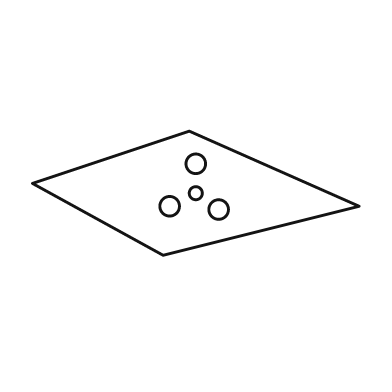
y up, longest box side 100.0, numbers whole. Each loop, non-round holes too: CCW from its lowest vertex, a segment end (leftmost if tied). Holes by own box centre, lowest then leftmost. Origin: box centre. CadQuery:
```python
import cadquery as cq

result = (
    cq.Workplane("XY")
    .moveTo(-10.0, -19.0)
    .lineTo(50.0, -4.0)
    .lineTo(-2.0, 19.0)
    .lineTo(-50.0, 3.0)
    .close()
    .moveTo(7.0, -5.0)
    .circle(3.0)
    .moveTo(-8.0, -4.0)
    .circle(3.0)
    .moveTo(0.0, 0.0)
    .circle(2.0)
    .moveTo(0.0, 9.0)
    .circle(3.0)
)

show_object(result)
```